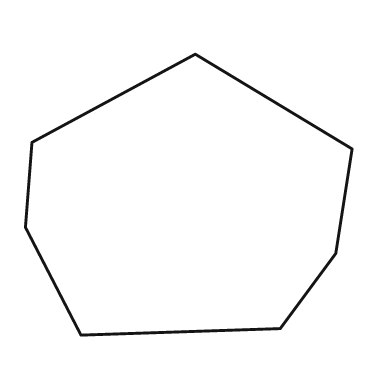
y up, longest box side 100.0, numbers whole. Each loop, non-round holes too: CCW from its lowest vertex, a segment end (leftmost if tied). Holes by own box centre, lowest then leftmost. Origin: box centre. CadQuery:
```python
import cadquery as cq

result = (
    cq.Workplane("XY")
    .moveTo(-33.0, -43.0)
    .lineTo(28.0, -41.0)
    .lineTo(45.0, -18.0)
    .lineTo(50.0, 14.0)
    .lineTo(2.0, 43.0)
    .lineTo(-48.0, 16.0)
    .lineTo(-50.0, -10.0)
    .close()
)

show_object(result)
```